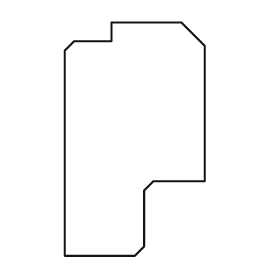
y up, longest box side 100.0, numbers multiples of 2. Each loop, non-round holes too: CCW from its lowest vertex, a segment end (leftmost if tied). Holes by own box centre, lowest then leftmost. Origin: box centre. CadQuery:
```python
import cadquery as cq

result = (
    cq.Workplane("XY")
    .moveTo(-30.0, -50.0)
    .lineTo(0.0, -50.0)
    .lineTo(4.0, -46.0)
    .lineTo(4.0, -22.0)
    .lineTo(8.0, -18.0)
    .lineTo(30.0, -18.0)
    .lineTo(30.0, 40.0)
    .lineTo(20.0, 50.0)
    .lineTo(-10.0, 50.0)
    .lineTo(-10.0, 42.0)
    .lineTo(-26.0, 42.0)
    .lineTo(-30.0, 38.0)
    .close()
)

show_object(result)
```